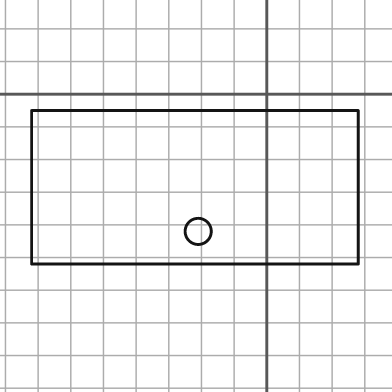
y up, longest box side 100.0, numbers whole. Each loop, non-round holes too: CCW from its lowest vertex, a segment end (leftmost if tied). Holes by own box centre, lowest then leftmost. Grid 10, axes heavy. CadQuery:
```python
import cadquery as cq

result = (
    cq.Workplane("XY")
    .moveTo(-72.0, -52.0)
    .lineTo(28.0, -52.0)
    .lineTo(28.0, -5.0)
    .lineTo(-72.0, -5.0)
    .close()
    .moveTo(-21.0, -42.0)
    .circle(4.0)
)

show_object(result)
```